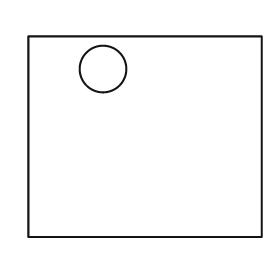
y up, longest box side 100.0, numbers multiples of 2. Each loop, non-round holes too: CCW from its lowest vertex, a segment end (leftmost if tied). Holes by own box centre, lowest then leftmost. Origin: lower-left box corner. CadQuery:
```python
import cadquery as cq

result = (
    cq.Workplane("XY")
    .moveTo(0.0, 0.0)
    .lineTo(100.0, 0.0)
    .lineTo(100.0, 86.0)
    .lineTo(0.0, 86.0)
    .close()
    .moveTo(32.0, 72.0)
    .circle(10.0)
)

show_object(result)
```